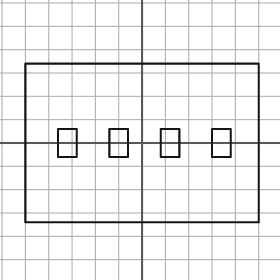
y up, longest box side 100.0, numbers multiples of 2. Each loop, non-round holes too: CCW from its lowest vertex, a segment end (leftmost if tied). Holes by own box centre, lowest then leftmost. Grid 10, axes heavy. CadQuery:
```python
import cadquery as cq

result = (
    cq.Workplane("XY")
    .moveTo(-50.0, -34.0)
    .lineTo(50.0, -34.0)
    .lineTo(50.0, 34.0)
    .lineTo(-50.0, 34.0)
    .close()
    .moveTo(-36.0, -6.0)
    .lineTo(-28.0, -6.0)
    .lineTo(-28.0, 6.0)
    .lineTo(-36.0, 6.0)
    .close()
    .moveTo(-14.0, -6.0)
    .lineTo(-6.0, -6.0)
    .lineTo(-6.0, 6.0)
    .lineTo(-14.0, 6.0)
    .close()
    .moveTo(8.0, -6.0)
    .lineTo(16.0, -6.0)
    .lineTo(16.0, 6.0)
    .lineTo(8.0, 6.0)
    .close()
    .moveTo(30.0, -6.0)
    .lineTo(38.0, -6.0)
    .lineTo(38.0, 6.0)
    .lineTo(30.0, 6.0)
    .close()
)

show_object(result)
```